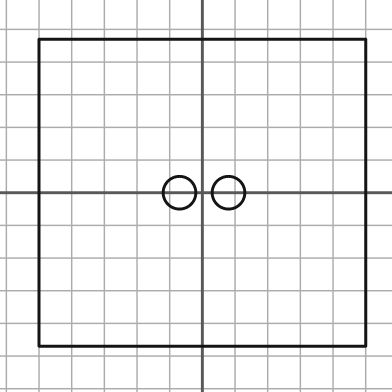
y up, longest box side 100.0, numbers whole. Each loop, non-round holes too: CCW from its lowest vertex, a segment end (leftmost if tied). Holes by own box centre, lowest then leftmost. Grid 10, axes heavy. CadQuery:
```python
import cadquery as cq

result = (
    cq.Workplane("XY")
    .moveTo(-50.0, -47.0)
    .lineTo(50.0, -47.0)
    .lineTo(50.0, 47.0)
    .lineTo(-50.0, 47.0)
    .close()
    .moveTo(-7.0, 0.0)
    .circle(5.0)
    .moveTo(8.0, 0.0)
    .circle(5.0)
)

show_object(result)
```